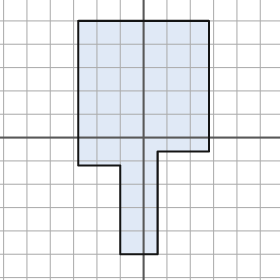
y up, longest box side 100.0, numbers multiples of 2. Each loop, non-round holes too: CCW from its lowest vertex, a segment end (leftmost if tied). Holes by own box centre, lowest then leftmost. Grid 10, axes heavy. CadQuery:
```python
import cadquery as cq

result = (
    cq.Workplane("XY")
    .moveTo(-10.0, -50.0)
    .lineTo(6.0, -50.0)
    .lineTo(6.0, -6.0)
    .lineTo(28.0, -6.0)
    .lineTo(28.0, 50.0)
    .lineTo(-28.0, 50.0)
    .lineTo(-28.0, -12.0)
    .lineTo(-10.0, -12.0)
    .close()
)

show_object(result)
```